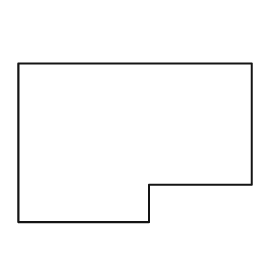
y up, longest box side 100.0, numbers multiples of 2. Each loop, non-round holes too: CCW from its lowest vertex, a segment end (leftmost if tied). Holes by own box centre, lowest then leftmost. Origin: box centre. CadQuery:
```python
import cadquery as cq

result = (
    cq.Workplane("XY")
    .moveTo(-50.0, -34.0)
    .lineTo(6.0, -34.0)
    .lineTo(6.0, -18.0)
    .lineTo(50.0, -18.0)
    .lineTo(50.0, 34.0)
    .lineTo(-50.0, 34.0)
    .close()
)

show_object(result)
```